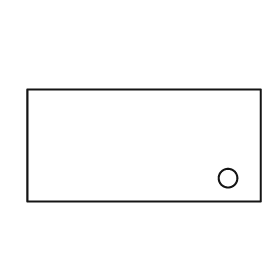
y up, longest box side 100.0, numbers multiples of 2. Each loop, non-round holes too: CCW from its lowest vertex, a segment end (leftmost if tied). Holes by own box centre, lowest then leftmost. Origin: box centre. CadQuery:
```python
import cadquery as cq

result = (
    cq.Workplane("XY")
    .moveTo(-50.0, -24.0)
    .lineTo(50.0, -24.0)
    .lineTo(50.0, 24.0)
    .lineTo(-50.0, 24.0)
    .close()
    .moveTo(36.0, -14.0)
    .circle(4.0)
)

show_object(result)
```